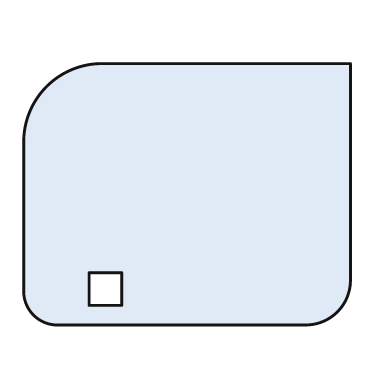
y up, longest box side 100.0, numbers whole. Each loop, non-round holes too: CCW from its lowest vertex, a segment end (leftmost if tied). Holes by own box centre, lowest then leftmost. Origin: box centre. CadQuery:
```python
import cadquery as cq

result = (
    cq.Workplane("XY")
    .moveTo(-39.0, -40.0)
    .lineTo(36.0, -40.0)
    .threePointArc((46.0, -36.0), (50.0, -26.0))
    .lineTo(50.0, 40.0)
    .lineTo(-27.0, 40.0)
    .threePointArc((-43.0, 33.0), (-50.0, 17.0))
    .lineTo(-50.0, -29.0)
    .threePointArc((-47.0, -37.0), (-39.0, -40.0))
    .close()
    .moveTo(-30.0, -34.0)
    .lineTo(-20.0, -34.0)
    .lineTo(-20.0, -24.0)
    .lineTo(-30.0, -24.0)
    .close()
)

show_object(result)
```